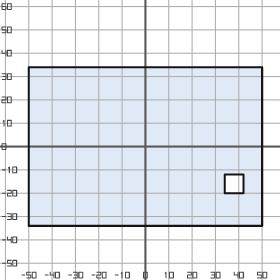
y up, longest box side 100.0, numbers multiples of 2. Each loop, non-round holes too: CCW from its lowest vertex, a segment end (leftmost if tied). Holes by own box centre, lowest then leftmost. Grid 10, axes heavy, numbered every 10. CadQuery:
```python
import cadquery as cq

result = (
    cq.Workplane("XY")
    .moveTo(-50.0, -34.0)
    .lineTo(50.0, -34.0)
    .lineTo(50.0, 34.0)
    .lineTo(-50.0, 34.0)
    .close()
    .moveTo(34.0, -20.0)
    .lineTo(42.0, -20.0)
    .lineTo(42.0, -12.0)
    .lineTo(34.0, -12.0)
    .close()
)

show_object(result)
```